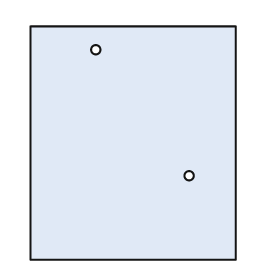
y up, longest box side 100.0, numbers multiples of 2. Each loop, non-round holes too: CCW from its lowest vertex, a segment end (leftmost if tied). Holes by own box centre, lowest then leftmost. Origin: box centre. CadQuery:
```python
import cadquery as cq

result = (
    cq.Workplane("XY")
    .moveTo(-44.0, -50.0)
    .lineTo(44.0, -50.0)
    .lineTo(44.0, 50.0)
    .lineTo(-44.0, 50.0)
    .close()
    .moveTo(24.0, -14.0)
    .circle(2.0)
    .moveTo(-16.0, 40.0)
    .circle(2.0)
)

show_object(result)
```